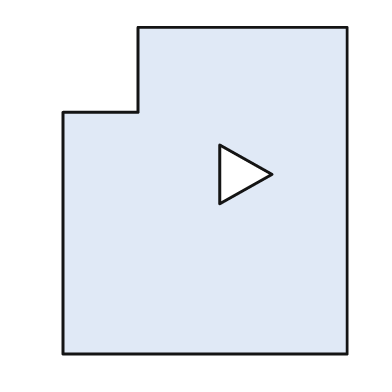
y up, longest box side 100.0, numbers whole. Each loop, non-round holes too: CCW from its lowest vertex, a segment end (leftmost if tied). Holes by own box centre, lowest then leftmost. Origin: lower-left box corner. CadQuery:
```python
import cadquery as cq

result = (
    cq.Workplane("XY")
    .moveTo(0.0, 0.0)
    .lineTo(87.0, 0.0)
    .lineTo(87.0, 100.0)
    .lineTo(23.0, 100.0)
    .lineTo(23.0, 74.0)
    .lineTo(0.0, 74.0)
    .close()
    .moveTo(48.0, 46.0)
    .lineTo(64.0, 55.0)
    .lineTo(48.0, 64.0)
    .close()
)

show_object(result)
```